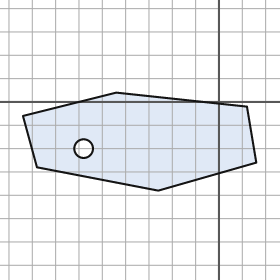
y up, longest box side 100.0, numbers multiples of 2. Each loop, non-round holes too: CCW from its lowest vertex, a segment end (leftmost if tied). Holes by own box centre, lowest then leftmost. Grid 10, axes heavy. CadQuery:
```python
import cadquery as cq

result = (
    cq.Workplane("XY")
    .moveTo(-26.0, -38.0)
    .lineTo(16.0, -26.0)
    .lineTo(12.0, -2.0)
    .lineTo(-44.0, 4.0)
    .lineTo(-84.0, -6.0)
    .lineTo(-78.0, -28.0)
    .close()
    .moveTo(-58.0, -20.0)
    .circle(4.0)
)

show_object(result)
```